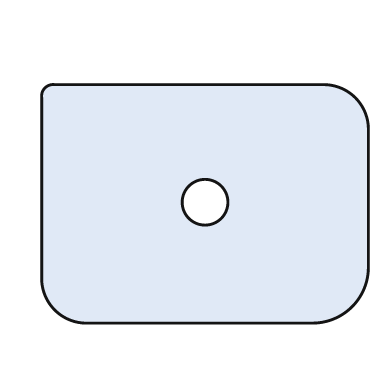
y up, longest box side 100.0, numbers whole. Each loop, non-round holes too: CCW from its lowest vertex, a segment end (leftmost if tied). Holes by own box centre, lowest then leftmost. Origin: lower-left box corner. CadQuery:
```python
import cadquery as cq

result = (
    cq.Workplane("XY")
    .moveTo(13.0, 0.0)
    .lineTo(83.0, 0.0)
    .threePointArc((95.0, 5.0), (100.0, 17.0))
    .lineTo(100.0, 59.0)
    .threePointArc((96.0, 69.0), (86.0, 73.0))
    .lineTo(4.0, 73.0)
    .threePointArc((1.0, 72.0), (0.0, 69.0))
    .lineTo(0.0, 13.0)
    .threePointArc((4.0, 4.0), (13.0, 0.0))
    .close()
    .moveTo(50.0, 37.0)
    .circle(7.0)
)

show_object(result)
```